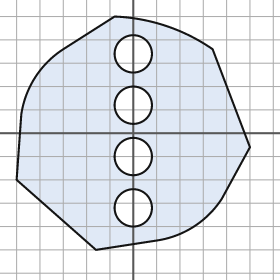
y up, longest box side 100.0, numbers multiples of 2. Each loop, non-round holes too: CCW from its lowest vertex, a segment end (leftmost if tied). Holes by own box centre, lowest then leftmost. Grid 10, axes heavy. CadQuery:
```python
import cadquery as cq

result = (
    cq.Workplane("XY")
    .moveTo(-16.0, -50.0)
    .lineTo(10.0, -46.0)
    .threePointArc((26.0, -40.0), (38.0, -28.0))
    .lineTo(50.0, -6.0)
    .lineTo(34.0, 36.0)
    .threePointArc((14.0, 46.0), (-8.0, 50.0))
    .lineTo(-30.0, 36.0)
    .threePointArc((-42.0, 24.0), (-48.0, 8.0))
    .lineTo(-50.0, -20.0)
    .close()
    .moveTo(0.0, -32.0)
    .circle(8.0)
    .moveTo(0.0, -10.0)
    .circle(8.0)
    .moveTo(0.0, 12.0)
    .circle(8.0)
    .moveTo(0.0, 34.0)
    .circle(8.0)
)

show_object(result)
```